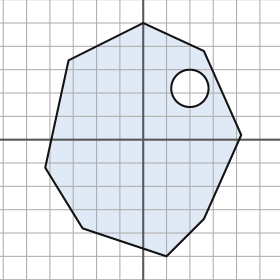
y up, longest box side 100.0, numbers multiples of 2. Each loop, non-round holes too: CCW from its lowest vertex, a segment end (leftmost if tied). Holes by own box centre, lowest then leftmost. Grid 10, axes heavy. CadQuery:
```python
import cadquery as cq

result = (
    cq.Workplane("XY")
    .moveTo(10.0, -50.0)
    .lineTo(26.0, -34.0)
    .lineTo(42.0, 2.0)
    .lineTo(26.0, 38.0)
    .lineTo(0.0, 50.0)
    .lineTo(-32.0, 34.0)
    .lineTo(-42.0, -12.0)
    .lineTo(-26.0, -38.0)
    .close()
    .moveTo(20.0, 22.0)
    .circle(8.0)
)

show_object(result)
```